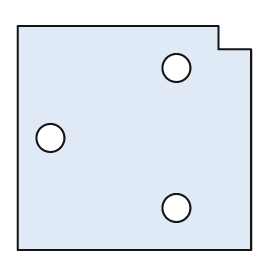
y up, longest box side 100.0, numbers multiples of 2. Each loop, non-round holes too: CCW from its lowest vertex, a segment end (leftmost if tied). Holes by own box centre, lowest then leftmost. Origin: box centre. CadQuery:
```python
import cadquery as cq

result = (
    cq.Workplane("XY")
    .moveTo(-50.0, -48.0)
    .lineTo(50.0, -48.0)
    .lineTo(50.0, 38.0)
    .lineTo(36.0, 38.0)
    .lineTo(36.0, 48.0)
    .lineTo(-50.0, 48.0)
    .close()
    .moveTo(18.0, -30.0)
    .circle(6.0)
    .moveTo(-36.0, 0.0)
    .circle(6.0)
    .moveTo(18.0, 30.0)
    .circle(6.0)
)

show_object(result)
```